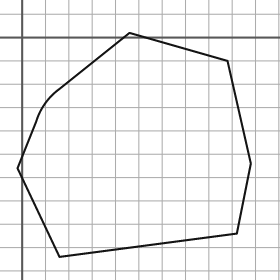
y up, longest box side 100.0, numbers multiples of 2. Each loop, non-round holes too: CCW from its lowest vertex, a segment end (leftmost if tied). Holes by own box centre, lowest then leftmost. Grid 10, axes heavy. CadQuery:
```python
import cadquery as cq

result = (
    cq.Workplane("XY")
    .moveTo(16.0, -94.0)
    .lineTo(92.0, -84.0)
    .lineTo(98.0, -54.0)
    .lineTo(88.0, -10.0)
    .lineTo(46.0, 2.0)
    .lineTo(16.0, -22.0)
    .threePointArc((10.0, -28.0), (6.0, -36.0))
    .lineTo(-2.0, -56.0)
    .close()
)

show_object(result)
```